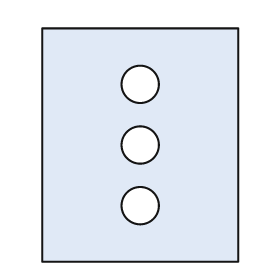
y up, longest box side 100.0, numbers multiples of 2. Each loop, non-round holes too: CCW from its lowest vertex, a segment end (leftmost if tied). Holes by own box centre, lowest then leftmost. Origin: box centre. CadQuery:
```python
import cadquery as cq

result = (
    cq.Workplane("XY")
    .moveTo(-42.0, -50.0)
    .lineTo(42.0, -50.0)
    .lineTo(42.0, 50.0)
    .lineTo(-42.0, 50.0)
    .close()
    .moveTo(0.0, -26.0)
    .circle(8.0)
    .moveTo(0.0, 0.0)
    .circle(8.0)
    .moveTo(0.0, 26.0)
    .circle(8.0)
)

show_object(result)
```